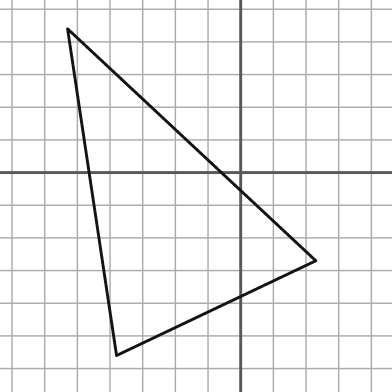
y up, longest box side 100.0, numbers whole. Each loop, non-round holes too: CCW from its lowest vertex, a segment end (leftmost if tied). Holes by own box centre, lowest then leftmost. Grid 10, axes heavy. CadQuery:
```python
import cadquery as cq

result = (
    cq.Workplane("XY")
    .moveTo(-38.0, -56.0)
    .lineTo(23.0, -27.0)
    .lineTo(-53.0, 44.0)
    .close()
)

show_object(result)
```